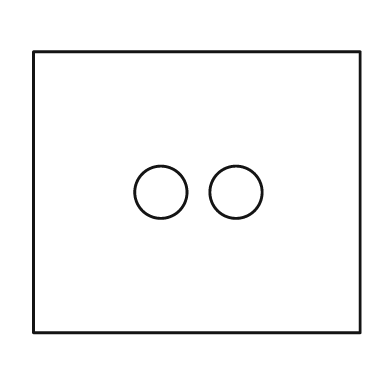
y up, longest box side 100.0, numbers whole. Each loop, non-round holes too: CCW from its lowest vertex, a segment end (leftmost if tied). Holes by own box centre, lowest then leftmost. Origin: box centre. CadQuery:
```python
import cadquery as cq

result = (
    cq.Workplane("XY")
    .moveTo(-50.0, -43.0)
    .lineTo(50.0, -43.0)
    .lineTo(50.0, 43.0)
    .lineTo(-50.0, 43.0)
    .close()
    .moveTo(-11.0, 0.0)
    .circle(8.0)
    .moveTo(12.0, 0.0)
    .circle(8.0)
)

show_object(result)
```